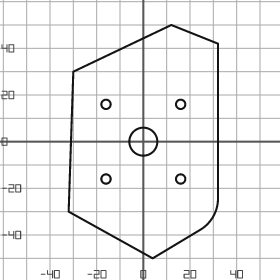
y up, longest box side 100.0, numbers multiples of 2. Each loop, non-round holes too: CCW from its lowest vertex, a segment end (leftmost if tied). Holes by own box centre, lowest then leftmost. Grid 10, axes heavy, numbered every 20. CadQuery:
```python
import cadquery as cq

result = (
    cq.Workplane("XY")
    .moveTo(4.0, -50.0)
    .lineTo(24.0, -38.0)
    .threePointArc((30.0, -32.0), (32.0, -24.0))
    .lineTo(32.0, 42.0)
    .lineTo(12.0, 50.0)
    .lineTo(-30.0, 30.0)
    .lineTo(-32.0, -30.0)
    .close()
    .moveTo(-16.0, -16.0)
    .circle(2.0)
    .moveTo(16.0, -16.0)
    .circle(2.0)
    .moveTo(0.0, 0.0)
    .circle(6.0)
    .moveTo(-16.0, 16.0)
    .circle(2.0)
    .moveTo(16.0, 16.0)
    .circle(2.0)
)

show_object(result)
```